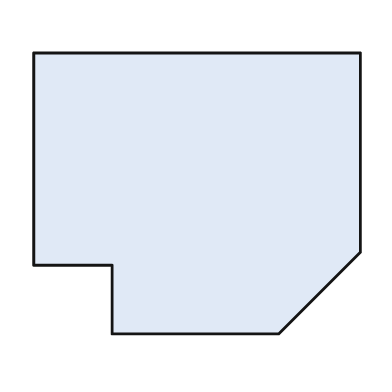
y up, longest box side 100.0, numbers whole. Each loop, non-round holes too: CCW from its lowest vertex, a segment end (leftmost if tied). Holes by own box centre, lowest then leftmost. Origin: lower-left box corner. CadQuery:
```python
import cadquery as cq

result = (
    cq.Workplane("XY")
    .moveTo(24.0, 0.0)
    .lineTo(75.0, 0.0)
    .lineTo(100.0, 25.0)
    .lineTo(100.0, 86.0)
    .lineTo(0.0, 86.0)
    .lineTo(0.0, 21.0)
    .lineTo(24.0, 21.0)
    .close()
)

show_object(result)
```